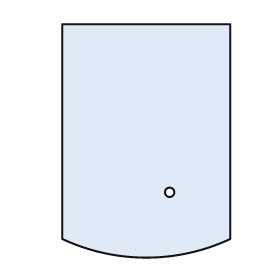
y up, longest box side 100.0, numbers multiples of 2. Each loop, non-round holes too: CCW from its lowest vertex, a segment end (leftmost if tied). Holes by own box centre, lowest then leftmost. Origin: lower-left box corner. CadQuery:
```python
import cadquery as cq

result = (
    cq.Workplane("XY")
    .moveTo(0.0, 8.0)
    .threePointArc((36.0, 0.0), (72.0, 8.0))
    .lineTo(72.0, 100.0)
    .lineTo(0.0, 100.0)
    .close()
    .moveTo(46.0, 28.0)
    .circle(2.0)
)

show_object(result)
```